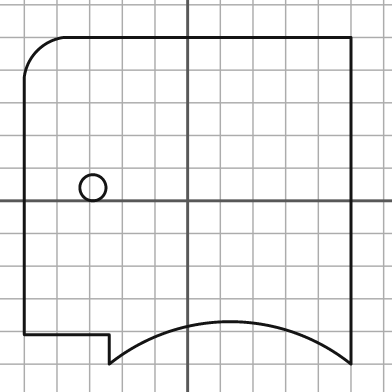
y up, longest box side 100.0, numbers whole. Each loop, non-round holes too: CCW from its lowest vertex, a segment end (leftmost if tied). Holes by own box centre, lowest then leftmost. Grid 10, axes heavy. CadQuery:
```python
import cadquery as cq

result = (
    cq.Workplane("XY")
    .moveTo(-24.0, -50.0)
    .threePointArc((13.0, -37.0), (50.0, -50.0))
    .lineTo(50.0, 50.0)
    .lineTo(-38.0, 50.0)
    .threePointArc((-46.0, 46.0), (-50.0, 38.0))
    .lineTo(-50.0, -41.0)
    .lineTo(-24.0, -41.0)
    .close()
    .moveTo(-29.0, 4.0)
    .circle(4.0)
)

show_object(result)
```